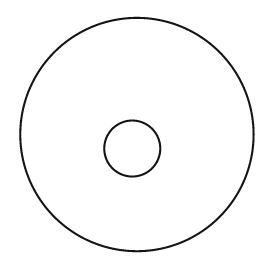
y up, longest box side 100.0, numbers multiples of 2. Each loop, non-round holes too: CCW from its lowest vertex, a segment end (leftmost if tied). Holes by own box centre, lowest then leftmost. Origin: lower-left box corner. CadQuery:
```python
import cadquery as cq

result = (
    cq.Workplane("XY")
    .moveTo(50.0, 50.0)
    .circle(50.0)
    .moveTo(48.0, 44.0)
    .circle(12.0)
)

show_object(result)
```